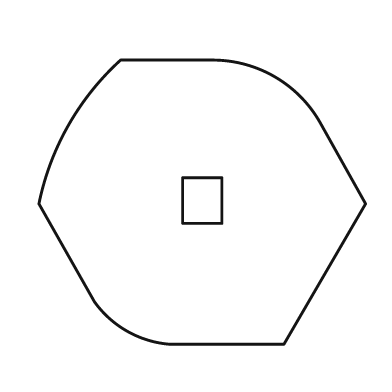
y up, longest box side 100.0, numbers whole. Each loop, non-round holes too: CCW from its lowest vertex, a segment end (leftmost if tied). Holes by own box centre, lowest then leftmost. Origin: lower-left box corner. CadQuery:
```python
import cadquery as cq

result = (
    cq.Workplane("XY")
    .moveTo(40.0, 0.0)
    .lineTo(75.0, 0.0)
    .lineTo(100.0, 43.0)
    .lineTo(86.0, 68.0)
    .threePointArc((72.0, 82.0), (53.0, 87.0))
    .lineTo(25.0, 87.0)
    .threePointArc((9.0, 67.0), (0.0, 43.0))
    .lineTo(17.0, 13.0)
    .threePointArc((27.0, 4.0), (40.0, 0.0))
    .close()
    .moveTo(44.0, 37.0)
    .lineTo(56.0, 37.0)
    .lineTo(56.0, 51.0)
    .lineTo(44.0, 51.0)
    .close()
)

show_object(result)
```